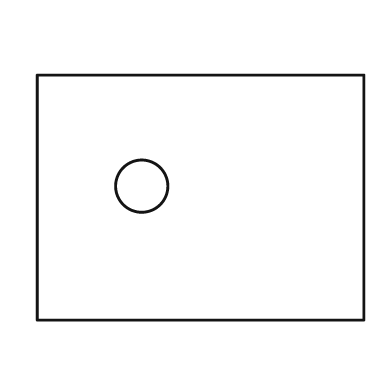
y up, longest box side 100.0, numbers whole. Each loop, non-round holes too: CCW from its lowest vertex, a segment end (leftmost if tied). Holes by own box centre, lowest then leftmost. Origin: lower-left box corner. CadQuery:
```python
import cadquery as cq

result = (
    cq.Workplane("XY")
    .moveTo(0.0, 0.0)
    .lineTo(100.0, 0.0)
    .lineTo(100.0, 75.0)
    .lineTo(0.0, 75.0)
    .close()
    .moveTo(32.0, 41.0)
    .circle(8.0)
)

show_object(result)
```